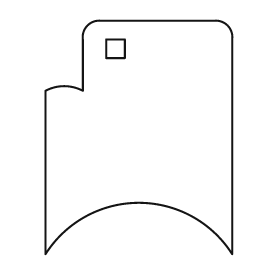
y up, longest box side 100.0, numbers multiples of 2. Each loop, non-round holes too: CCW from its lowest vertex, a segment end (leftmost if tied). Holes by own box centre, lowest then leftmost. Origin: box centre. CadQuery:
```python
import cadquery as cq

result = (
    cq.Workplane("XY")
    .moveTo(-40.0, -50.0)
    .threePointArc((0.0, -28.0), (40.0, -50.0))
    .lineTo(40.0, 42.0)
    .threePointArc((38.0, 48.0), (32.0, 50.0))
    .lineTo(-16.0, 50.0)
    .threePointArc((-22.0, 48.0), (-24.0, 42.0))
    .lineTo(-24.0, 20.0)
    .threePointArc((-32.0, 22.0), (-40.0, 20.0))
    .close()
    .moveTo(-14.0, 34.0)
    .lineTo(-6.0, 34.0)
    .lineTo(-6.0, 42.0)
    .lineTo(-14.0, 42.0)
    .close()
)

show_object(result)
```